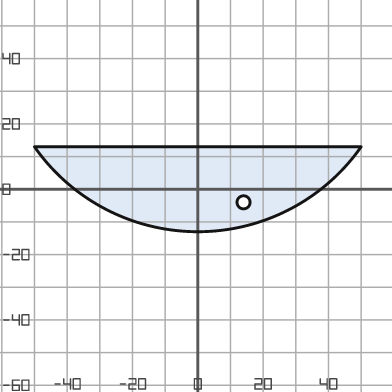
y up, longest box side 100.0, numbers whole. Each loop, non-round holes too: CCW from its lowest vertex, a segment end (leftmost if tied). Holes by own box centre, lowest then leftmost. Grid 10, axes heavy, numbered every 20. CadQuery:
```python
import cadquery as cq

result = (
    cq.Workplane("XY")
    .moveTo(-50.0, 13.0)
    .threePointArc((0.0, -13.0), (50.0, 13.0))
    .close()
    .moveTo(14.0, -4.0)
    .circle(2.0)
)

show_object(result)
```